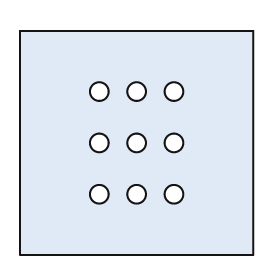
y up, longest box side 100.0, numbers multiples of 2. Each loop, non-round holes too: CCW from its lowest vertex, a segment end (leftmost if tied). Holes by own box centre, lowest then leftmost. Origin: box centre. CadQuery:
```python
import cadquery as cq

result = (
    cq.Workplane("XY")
    .moveTo(-50.0, -48.0)
    .lineTo(50.0, -48.0)
    .lineTo(50.0, 48.0)
    .lineTo(-50.0, 48.0)
    .close()
    .moveTo(-16.0, -22.0)
    .circle(4.0)
    .moveTo(0.0, -22.0)
    .circle(4.0)
    .moveTo(16.0, -22.0)
    .circle(4.0)
    .moveTo(-16.0, 0.0)
    .circle(4.0)
    .moveTo(0.0, 0.0)
    .circle(4.0)
    .moveTo(16.0, 0.0)
    .circle(4.0)
    .moveTo(-16.0, 22.0)
    .circle(4.0)
    .moveTo(0.0, 22.0)
    .circle(4.0)
    .moveTo(16.0, 22.0)
    .circle(4.0)
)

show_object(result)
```